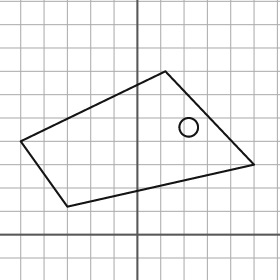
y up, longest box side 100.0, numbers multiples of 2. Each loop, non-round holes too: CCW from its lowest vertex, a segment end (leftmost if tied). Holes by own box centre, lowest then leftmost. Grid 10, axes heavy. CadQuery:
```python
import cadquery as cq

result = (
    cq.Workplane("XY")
    .moveTo(-30.0, 12.0)
    .lineTo(50.0, 30.0)
    .lineTo(12.0, 70.0)
    .lineTo(-50.0, 40.0)
    .close()
    .moveTo(22.0, 46.0)
    .circle(4.0)
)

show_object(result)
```